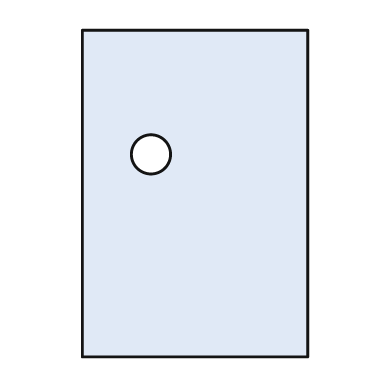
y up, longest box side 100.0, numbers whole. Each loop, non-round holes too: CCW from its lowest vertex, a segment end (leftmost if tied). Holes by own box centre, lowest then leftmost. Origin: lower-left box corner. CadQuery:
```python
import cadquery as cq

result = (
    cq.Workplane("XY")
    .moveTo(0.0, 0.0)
    .lineTo(69.0, 0.0)
    .lineTo(69.0, 100.0)
    .lineTo(0.0, 100.0)
    .close()
    .moveTo(21.0, 62.0)
    .circle(6.0)
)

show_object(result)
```